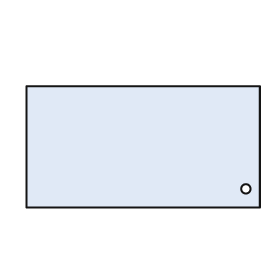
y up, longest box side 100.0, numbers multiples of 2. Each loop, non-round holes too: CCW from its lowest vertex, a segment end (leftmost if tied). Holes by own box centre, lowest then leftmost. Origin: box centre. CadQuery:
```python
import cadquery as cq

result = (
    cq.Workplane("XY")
    .moveTo(-50.0, -26.0)
    .lineTo(50.0, -26.0)
    .lineTo(50.0, 26.0)
    .lineTo(-50.0, 26.0)
    .close()
    .moveTo(44.0, -18.0)
    .circle(2.0)
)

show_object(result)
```